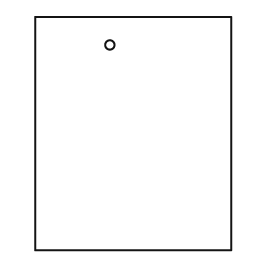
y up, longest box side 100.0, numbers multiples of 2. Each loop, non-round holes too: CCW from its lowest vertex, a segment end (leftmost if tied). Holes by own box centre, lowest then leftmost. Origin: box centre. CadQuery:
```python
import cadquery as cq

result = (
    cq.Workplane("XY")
    .moveTo(-42.0, -50.0)
    .lineTo(42.0, -50.0)
    .lineTo(42.0, 50.0)
    .lineTo(-42.0, 50.0)
    .close()
    .moveTo(-10.0, 38.0)
    .circle(2.0)
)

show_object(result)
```